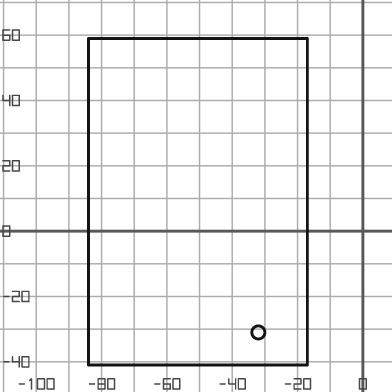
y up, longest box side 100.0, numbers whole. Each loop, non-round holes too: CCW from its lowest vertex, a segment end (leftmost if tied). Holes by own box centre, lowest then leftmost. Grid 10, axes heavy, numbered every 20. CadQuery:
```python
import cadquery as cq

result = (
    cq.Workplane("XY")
    .moveTo(-84.0, -41.0)
    .lineTo(-17.0, -41.0)
    .lineTo(-17.0, 59.0)
    .lineTo(-84.0, 59.0)
    .close()
    .moveTo(-32.0, -31.0)
    .circle(2.0)
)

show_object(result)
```